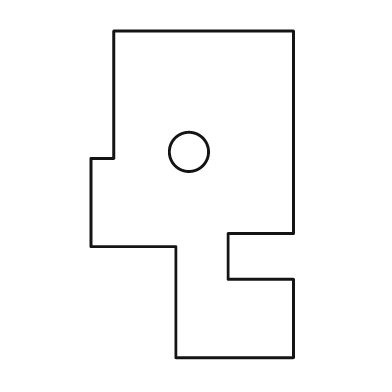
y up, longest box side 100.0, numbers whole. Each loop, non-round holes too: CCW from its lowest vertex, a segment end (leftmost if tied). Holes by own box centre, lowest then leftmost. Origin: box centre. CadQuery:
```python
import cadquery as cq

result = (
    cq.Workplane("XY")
    .moveTo(-5.0, -50.0)
    .lineTo(31.0, -50.0)
    .lineTo(31.0, -26.0)
    .lineTo(11.0, -26.0)
    .lineTo(11.0, -12.0)
    .lineTo(31.0, -12.0)
    .lineTo(31.0, 50.0)
    .lineTo(-24.0, 50.0)
    .lineTo(-24.0, 11.0)
    .lineTo(-31.0, 11.0)
    .lineTo(-31.0, -16.0)
    .lineTo(-5.0, -16.0)
    .close()
    .moveTo(-1.0, 13.0)
    .circle(6.0)
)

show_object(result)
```